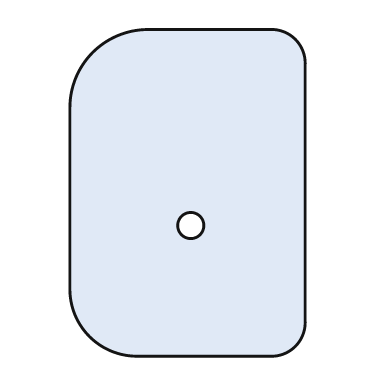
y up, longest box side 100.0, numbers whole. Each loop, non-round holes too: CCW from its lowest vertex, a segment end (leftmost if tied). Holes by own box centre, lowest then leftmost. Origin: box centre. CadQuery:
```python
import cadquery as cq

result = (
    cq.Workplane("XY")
    .moveTo(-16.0, -50.0)
    .lineTo(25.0, -50.0)
    .threePointArc((33.0, -47.0), (36.0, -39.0))
    .lineTo(36.0, 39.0)
    .threePointArc((33.0, 47.0), (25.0, 50.0))
    .lineTo(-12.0, 50.0)
    .threePointArc((-29.0, 43.0), (-36.0, 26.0))
    .lineTo(-36.0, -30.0)
    .threePointArc((-30.0, -44.0), (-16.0, -50.0))
    .close()
    .moveTo(1.0, -10.0)
    .circle(4.0)
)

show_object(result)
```